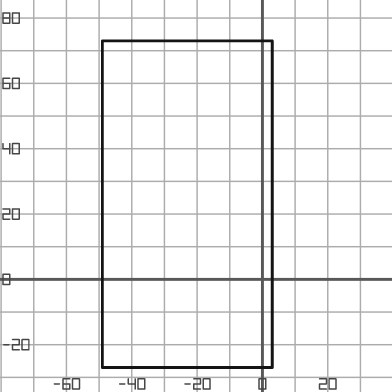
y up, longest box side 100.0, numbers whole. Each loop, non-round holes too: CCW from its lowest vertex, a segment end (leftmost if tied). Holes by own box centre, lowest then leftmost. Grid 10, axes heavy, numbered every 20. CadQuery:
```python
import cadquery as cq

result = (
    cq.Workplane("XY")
    .moveTo(-49.0, -27.0)
    .lineTo(3.0, -27.0)
    .lineTo(3.0, 73.0)
    .lineTo(-49.0, 73.0)
    .close()
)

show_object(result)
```